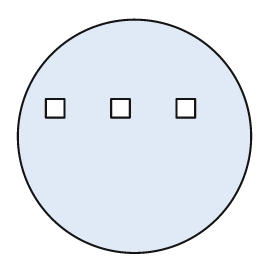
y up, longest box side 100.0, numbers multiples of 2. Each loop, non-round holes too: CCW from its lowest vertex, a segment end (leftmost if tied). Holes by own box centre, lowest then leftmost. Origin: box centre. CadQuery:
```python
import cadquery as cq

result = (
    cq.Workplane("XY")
    .moveTo(0.0, 0.0)
    .circle(50.0)
    .moveTo(-38.0, 8.0)
    .lineTo(-30.0, 8.0)
    .lineTo(-30.0, 16.0)
    .lineTo(-38.0, 16.0)
    .close()
    .moveTo(-10.0, 8.0)
    .lineTo(-2.0, 8.0)
    .lineTo(-2.0, 16.0)
    .lineTo(-10.0, 16.0)
    .close()
    .moveTo(18.0, 8.0)
    .lineTo(26.0, 8.0)
    .lineTo(26.0, 16.0)
    .lineTo(18.0, 16.0)
    .close()
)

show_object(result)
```